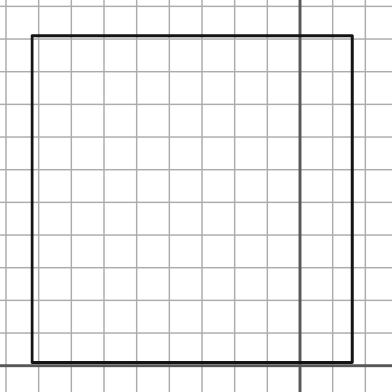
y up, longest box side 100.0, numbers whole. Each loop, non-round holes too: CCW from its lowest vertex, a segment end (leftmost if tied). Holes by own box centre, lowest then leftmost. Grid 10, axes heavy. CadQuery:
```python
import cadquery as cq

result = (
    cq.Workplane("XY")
    .moveTo(-82.0, 1.0)
    .lineTo(16.0, 1.0)
    .lineTo(16.0, 101.0)
    .lineTo(-82.0, 101.0)
    .close()
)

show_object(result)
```